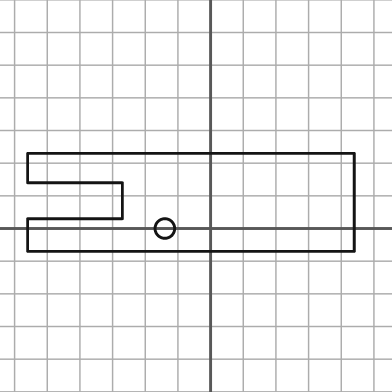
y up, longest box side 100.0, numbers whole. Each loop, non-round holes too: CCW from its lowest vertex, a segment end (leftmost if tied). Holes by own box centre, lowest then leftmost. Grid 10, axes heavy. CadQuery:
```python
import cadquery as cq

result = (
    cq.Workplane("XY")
    .moveTo(-56.0, -7.0)
    .lineTo(44.0, -7.0)
    .lineTo(44.0, 23.0)
    .lineTo(-56.0, 23.0)
    .lineTo(-56.0, 14.0)
    .lineTo(-27.0, 14.0)
    .lineTo(-27.0, 3.0)
    .lineTo(-56.0, 3.0)
    .close()
    .moveTo(-14.0, 0.0)
    .circle(3.0)
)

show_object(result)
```